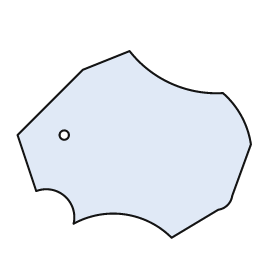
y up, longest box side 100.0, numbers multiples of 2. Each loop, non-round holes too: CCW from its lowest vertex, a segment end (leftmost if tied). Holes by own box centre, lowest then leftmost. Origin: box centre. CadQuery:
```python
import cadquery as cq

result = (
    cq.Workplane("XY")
    .moveTo(16.0, -40.0)
    .lineTo(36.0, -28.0)
    .threePointArc((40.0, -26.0), (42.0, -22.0))
    .lineTo(50.0, 0.0)
    .threePointArc((46.0, 12.0), (38.0, 22.0))
    .threePointArc((16.0, 26.0), (-2.0, 40.0))
    .lineTo(-22.0, 32.0)
    .lineTo(-50.0, 4.0)
    .lineTo(-42.0, -20.0)
    .threePointArc((-30.0, -22.0), (-26.0, -34.0))
    .threePointArc((-4.0, -30.0), (16.0, -40.0))
    .close()
    .moveTo(-30.0, 4.0)
    .circle(2.0)
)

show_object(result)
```